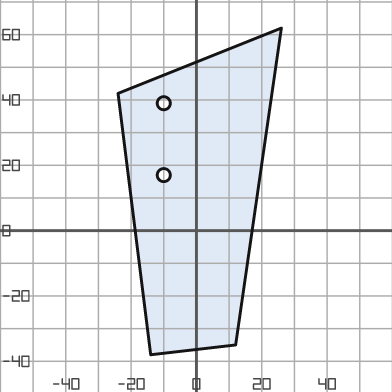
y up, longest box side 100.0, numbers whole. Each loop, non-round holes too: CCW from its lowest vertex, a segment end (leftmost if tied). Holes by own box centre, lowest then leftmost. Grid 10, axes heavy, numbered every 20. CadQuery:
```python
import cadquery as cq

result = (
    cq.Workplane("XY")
    .moveTo(-14.0, -38.0)
    .lineTo(12.0, -35.0)
    .lineTo(26.0, 62.0)
    .lineTo(-24.0, 42.0)
    .close()
    .moveTo(-10.0, 17.0)
    .circle(2.0)
    .moveTo(-10.0, 39.0)
    .circle(2.0)
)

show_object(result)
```